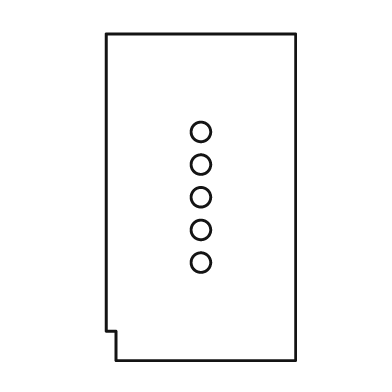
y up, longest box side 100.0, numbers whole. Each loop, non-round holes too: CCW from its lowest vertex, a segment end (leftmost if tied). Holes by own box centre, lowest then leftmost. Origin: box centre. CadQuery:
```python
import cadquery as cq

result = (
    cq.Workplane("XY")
    .moveTo(-26.0, -50.0)
    .lineTo(29.0, -50.0)
    .lineTo(29.0, 50.0)
    .lineTo(-29.0, 50.0)
    .lineTo(-29.0, -41.0)
    .lineTo(-26.0, -41.0)
    .close()
    .moveTo(0.0, -20.0)
    .circle(3.0)
    .moveTo(0.0, -10.0)
    .circle(3.0)
    .moveTo(0.0, 0.0)
    .circle(3.0)
    .moveTo(0.0, 10.0)
    .circle(3.0)
    .moveTo(0.0, 20.0)
    .circle(3.0)
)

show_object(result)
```